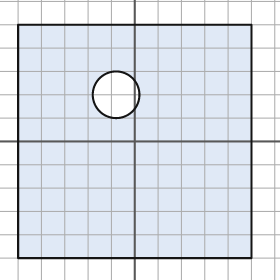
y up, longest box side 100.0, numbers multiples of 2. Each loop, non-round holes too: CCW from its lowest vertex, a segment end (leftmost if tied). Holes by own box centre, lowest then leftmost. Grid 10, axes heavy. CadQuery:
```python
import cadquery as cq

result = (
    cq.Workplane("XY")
    .moveTo(-50.0, -50.0)
    .lineTo(50.0, -50.0)
    .lineTo(50.0, 50.0)
    .lineTo(-50.0, 50.0)
    .close()
    .moveTo(-8.0, 20.0)
    .circle(10.0)
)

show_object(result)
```